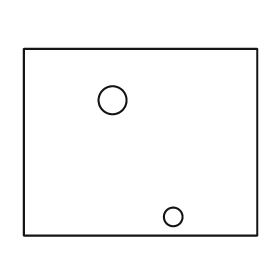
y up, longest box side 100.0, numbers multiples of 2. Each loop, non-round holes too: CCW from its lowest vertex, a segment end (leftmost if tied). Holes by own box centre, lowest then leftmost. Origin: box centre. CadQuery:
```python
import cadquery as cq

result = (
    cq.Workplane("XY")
    .moveTo(-50.0, -40.0)
    .lineTo(50.0, -40.0)
    .lineTo(50.0, 40.0)
    .lineTo(-50.0, 40.0)
    .close()
    .moveTo(14.0, -32.0)
    .circle(4.0)
    .moveTo(-12.0, 18.0)
    .circle(6.0)
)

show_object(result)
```